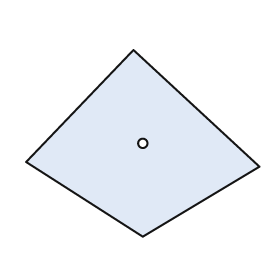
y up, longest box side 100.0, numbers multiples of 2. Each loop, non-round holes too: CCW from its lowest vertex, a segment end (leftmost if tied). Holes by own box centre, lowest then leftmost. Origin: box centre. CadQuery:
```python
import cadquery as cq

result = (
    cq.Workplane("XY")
    .moveTo(0.0, -40.0)
    .lineTo(50.0, -10.0)
    .lineTo(-4.0, 40.0)
    .lineTo(-50.0, -8.0)
    .close()
    .moveTo(0.0, 0.0)
    .circle(2.0)
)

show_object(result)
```